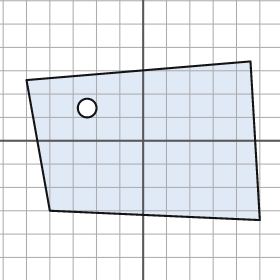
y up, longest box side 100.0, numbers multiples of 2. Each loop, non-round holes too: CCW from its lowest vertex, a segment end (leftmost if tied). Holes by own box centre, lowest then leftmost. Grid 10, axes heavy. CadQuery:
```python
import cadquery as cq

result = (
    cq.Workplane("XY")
    .moveTo(50.0, -34.0)
    .lineTo(46.0, 34.0)
    .lineTo(-50.0, 26.0)
    .lineTo(-40.0, -30.0)
    .close()
    .moveTo(-24.0, 14.0)
    .circle(4.0)
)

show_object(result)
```